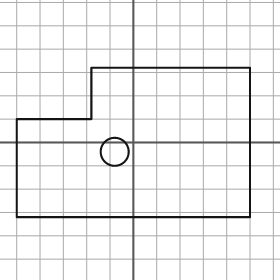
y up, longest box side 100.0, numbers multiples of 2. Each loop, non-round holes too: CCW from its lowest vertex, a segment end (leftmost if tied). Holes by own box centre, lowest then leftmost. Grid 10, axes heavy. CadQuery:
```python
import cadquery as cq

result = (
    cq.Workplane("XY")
    .moveTo(-50.0, -32.0)
    .lineTo(50.0, -32.0)
    .lineTo(50.0, 32.0)
    .lineTo(-18.0, 32.0)
    .lineTo(-18.0, 10.0)
    .lineTo(-50.0, 10.0)
    .close()
    .moveTo(-8.0, -4.0)
    .circle(6.0)
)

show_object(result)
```